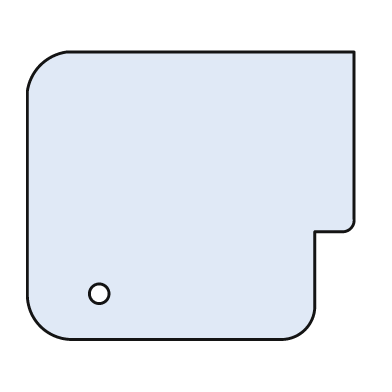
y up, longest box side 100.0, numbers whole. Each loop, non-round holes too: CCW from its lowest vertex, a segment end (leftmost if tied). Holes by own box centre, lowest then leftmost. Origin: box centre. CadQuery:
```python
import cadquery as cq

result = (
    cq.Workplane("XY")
    .moveTo(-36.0, -44.0)
    .lineTo(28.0, -44.0)
    .threePointArc((35.0, -41.0), (38.0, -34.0))
    .lineTo(38.0, -11.0)
    .lineTo(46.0, -11.0)
    .threePointArc((49.0, -10.0), (50.0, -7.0))
    .lineTo(50.0, 44.0)
    .lineTo(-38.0, 44.0)
    .threePointArc((-46.0, 40.0), (-50.0, 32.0))
    .lineTo(-50.0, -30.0)
    .threePointArc((-46.0, -40.0), (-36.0, -44.0))
    .close()
    .moveTo(-28.0, -30.0)
    .circle(3.0)
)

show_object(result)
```